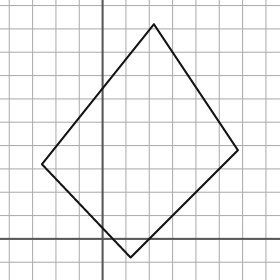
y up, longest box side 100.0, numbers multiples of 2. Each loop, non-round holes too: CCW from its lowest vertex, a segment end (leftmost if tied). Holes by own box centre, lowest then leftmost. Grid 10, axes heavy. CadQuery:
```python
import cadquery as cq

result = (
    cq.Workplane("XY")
    .moveTo(12.0, -8.0)
    .lineTo(58.0, 38.0)
    .lineTo(22.0, 92.0)
    .lineTo(-26.0, 32.0)
    .close()
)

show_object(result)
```